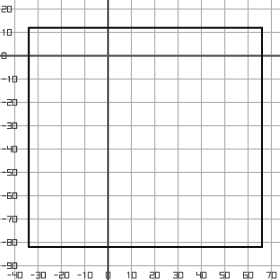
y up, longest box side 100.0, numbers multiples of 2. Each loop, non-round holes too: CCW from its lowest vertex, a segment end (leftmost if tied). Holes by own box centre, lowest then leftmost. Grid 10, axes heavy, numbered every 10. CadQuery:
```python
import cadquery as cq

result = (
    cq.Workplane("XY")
    .moveTo(-34.0, -82.0)
    .lineTo(66.0, -82.0)
    .lineTo(66.0, 12.0)
    .lineTo(-34.0, 12.0)
    .close()
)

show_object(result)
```